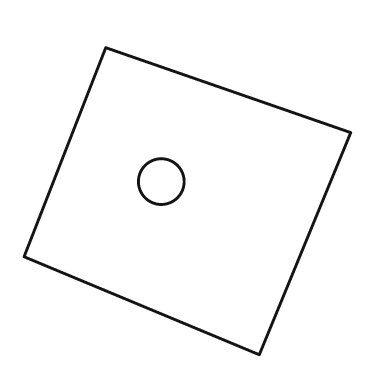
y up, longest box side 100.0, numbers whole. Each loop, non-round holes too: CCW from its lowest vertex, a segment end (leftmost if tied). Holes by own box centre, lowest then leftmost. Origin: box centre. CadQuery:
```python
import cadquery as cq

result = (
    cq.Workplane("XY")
    .moveTo(22.0, -47.0)
    .lineTo(50.0, 21.0)
    .lineTo(-25.0, 47.0)
    .lineTo(-50.0, -17.0)
    .close()
    .moveTo(-8.0, 6.0)
    .circle(7.0)
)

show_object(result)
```